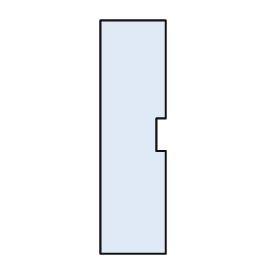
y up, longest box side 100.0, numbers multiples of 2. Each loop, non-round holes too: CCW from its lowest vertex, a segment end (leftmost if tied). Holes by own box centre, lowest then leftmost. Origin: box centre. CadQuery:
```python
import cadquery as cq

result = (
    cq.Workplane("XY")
    .moveTo(-14.0, -50.0)
    .lineTo(14.0, -50.0)
    .lineTo(14.0, -6.0)
    .lineTo(10.0, -6.0)
    .lineTo(10.0, 8.0)
    .lineTo(14.0, 8.0)
    .lineTo(14.0, 50.0)
    .lineTo(-14.0, 50.0)
    .close()
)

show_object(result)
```